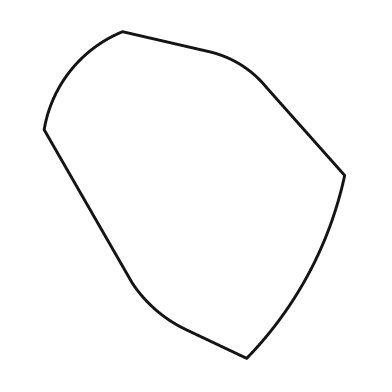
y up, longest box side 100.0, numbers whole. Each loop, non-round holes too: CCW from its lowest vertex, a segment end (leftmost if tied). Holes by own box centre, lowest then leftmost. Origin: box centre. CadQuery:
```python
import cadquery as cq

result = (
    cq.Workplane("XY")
    .moveTo(16.0, -50.0)
    .threePointArc((35.0, -24.0), (46.0, 6.0))
    .lineTo(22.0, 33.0)
    .threePointArc((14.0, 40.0), (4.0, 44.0))
    .lineTo(-22.0, 50.0)
    .threePointArc((-38.0, 38.0), (-46.0, 20.0))
    .lineTo(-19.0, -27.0)
    .threePointArc((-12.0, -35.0), (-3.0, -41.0))
    .close()
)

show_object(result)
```